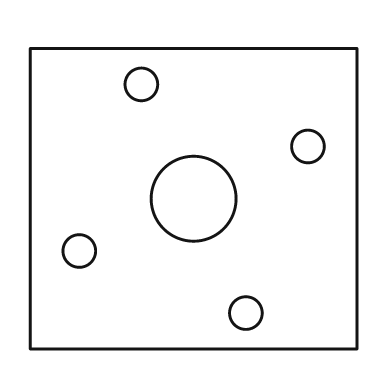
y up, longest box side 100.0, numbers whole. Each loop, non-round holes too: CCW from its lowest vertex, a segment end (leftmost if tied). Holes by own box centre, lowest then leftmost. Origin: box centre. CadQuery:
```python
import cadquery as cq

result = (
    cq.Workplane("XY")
    .moveTo(-50.0, -46.0)
    .lineTo(50.0, -46.0)
    .lineTo(50.0, 46.0)
    .lineTo(-50.0, 46.0)
    .close()
    .moveTo(16.0, -35.0)
    .circle(5.0)
    .moveTo(-35.0, -16.0)
    .circle(5.0)
    .moveTo(0.0, 0.0)
    .circle(13.0)
    .moveTo(35.0, 16.0)
    .circle(5.0)
    .moveTo(-16.0, 35.0)
    .circle(5.0)
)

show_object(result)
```